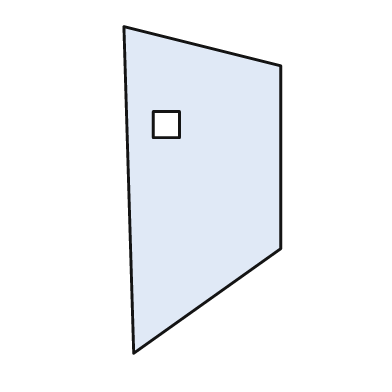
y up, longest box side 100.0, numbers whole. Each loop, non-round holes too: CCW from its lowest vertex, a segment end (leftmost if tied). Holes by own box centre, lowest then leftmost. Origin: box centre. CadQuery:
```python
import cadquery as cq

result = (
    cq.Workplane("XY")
    .moveTo(-21.0, -50.0)
    .lineTo(24.0, -18.0)
    .lineTo(24.0, 38.0)
    .lineTo(-24.0, 50.0)
    .close()
    .moveTo(-15.0, 16.0)
    .lineTo(-7.0, 16.0)
    .lineTo(-7.0, 24.0)
    .lineTo(-15.0, 24.0)
    .close()
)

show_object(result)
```